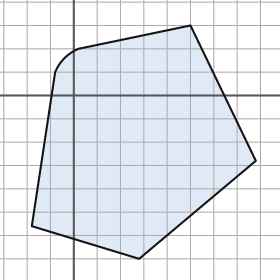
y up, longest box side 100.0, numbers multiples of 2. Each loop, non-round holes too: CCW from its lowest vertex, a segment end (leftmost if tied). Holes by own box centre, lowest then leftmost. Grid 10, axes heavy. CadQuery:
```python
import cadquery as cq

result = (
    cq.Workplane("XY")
    .moveTo(28.0, -70.0)
    .lineTo(78.0, -28.0)
    .lineTo(50.0, 30.0)
    .lineTo(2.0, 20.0)
    .threePointArc((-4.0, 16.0), (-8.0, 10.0))
    .lineTo(-18.0, -56.0)
    .close()
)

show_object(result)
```